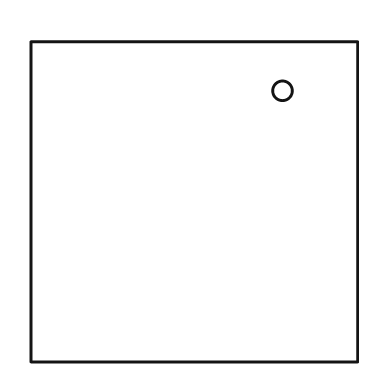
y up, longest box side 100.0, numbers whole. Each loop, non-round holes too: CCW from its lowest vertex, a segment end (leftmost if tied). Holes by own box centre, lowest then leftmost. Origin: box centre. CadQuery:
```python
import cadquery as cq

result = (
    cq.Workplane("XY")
    .moveTo(-50.0, -49.0)
    .lineTo(50.0, -49.0)
    .lineTo(50.0, 49.0)
    .lineTo(-50.0, 49.0)
    .close()
    .moveTo(27.0, 34.0)
    .circle(3.0)
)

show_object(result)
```